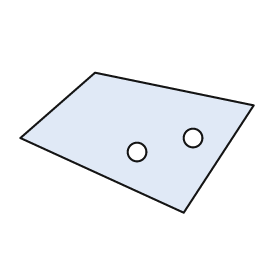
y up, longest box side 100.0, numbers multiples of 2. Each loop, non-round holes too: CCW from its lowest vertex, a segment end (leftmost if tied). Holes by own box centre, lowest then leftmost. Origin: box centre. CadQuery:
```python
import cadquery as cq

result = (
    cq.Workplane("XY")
    .moveTo(20.0, -30.0)
    .lineTo(50.0, 16.0)
    .lineTo(-18.0, 30.0)
    .lineTo(-50.0, 2.0)
    .close()
    .moveTo(0.0, -4.0)
    .circle(4.0)
    .moveTo(24.0, 2.0)
    .circle(4.0)
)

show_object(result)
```